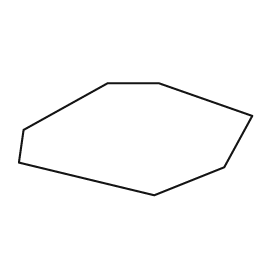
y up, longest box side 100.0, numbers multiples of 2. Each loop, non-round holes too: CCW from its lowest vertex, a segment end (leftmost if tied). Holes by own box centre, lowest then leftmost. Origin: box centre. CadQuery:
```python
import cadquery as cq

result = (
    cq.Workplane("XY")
    .moveTo(8.0, -24.0)
    .lineTo(38.0, -12.0)
    .lineTo(50.0, 10.0)
    .lineTo(10.0, 24.0)
    .lineTo(-12.0, 24.0)
    .lineTo(-48.0, 4.0)
    .lineTo(-50.0, -10.0)
    .close()
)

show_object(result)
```